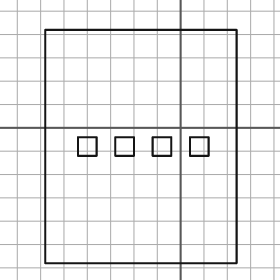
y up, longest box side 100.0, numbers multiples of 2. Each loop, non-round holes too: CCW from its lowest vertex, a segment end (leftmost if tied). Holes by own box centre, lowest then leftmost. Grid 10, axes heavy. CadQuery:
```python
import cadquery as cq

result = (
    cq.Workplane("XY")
    .moveTo(-58.0, -58.0)
    .lineTo(24.0, -58.0)
    .lineTo(24.0, 42.0)
    .lineTo(-58.0, 42.0)
    .close()
    .moveTo(-44.0, -12.0)
    .lineTo(-36.0, -12.0)
    .lineTo(-36.0, -4.0)
    .lineTo(-44.0, -4.0)
    .close()
    .moveTo(-28.0, -12.0)
    .lineTo(-20.0, -12.0)
    .lineTo(-20.0, -4.0)
    .lineTo(-28.0, -4.0)
    .close()
    .moveTo(-12.0, -12.0)
    .lineTo(-4.0, -12.0)
    .lineTo(-4.0, -4.0)
    .lineTo(-12.0, -4.0)
    .close()
    .moveTo(4.0, -12.0)
    .lineTo(12.0, -12.0)
    .lineTo(12.0, -4.0)
    .lineTo(4.0, -4.0)
    .close()
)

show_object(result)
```